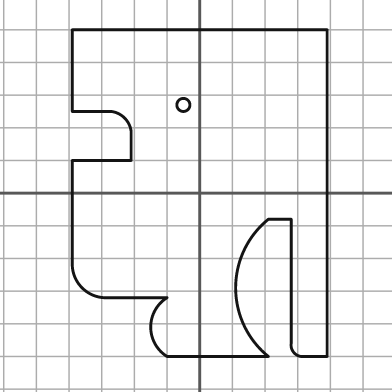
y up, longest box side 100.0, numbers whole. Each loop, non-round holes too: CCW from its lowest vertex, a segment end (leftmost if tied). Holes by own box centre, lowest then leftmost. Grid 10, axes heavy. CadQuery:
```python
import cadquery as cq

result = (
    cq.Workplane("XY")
    .moveTo(-10.0, -50.0)
    .lineTo(21.0, -50.0)
    .threePointArc((11.0, -29.0), (21.0, -8.0))
    .lineTo(28.0, -8.0)
    .lineTo(28.0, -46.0)
    .threePointArc((29.0, -49.0), (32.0, -50.0))
    .lineTo(39.0, -50.0)
    .lineTo(39.0, 50.0)
    .lineTo(-39.0, 50.0)
    .lineTo(-39.0, 25.0)
    .lineTo(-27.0, 25.0)
    .threePointArc((-23.0, 23.0), (-21.0, 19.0))
    .lineTo(-21.0, 10.0)
    .lineTo(-39.0, 10.0)
    .lineTo(-39.0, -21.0)
    .threePointArc((-36.0, -29.0), (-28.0, -32.0))
    .lineTo(-10.0, -32.0)
    .threePointArc((-15.0, -41.0), (-10.0, -50.0))
    .close()
    .moveTo(-5.0, 27.0)
    .circle(2.0)
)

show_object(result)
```